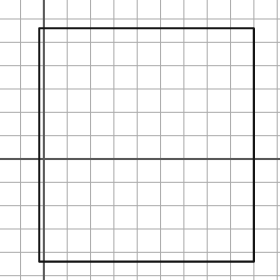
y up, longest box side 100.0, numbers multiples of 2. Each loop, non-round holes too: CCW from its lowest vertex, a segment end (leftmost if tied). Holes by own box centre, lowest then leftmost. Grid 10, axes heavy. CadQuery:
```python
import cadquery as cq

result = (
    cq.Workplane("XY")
    .moveTo(-2.0, -44.0)
    .lineTo(90.0, -44.0)
    .lineTo(90.0, 56.0)
    .lineTo(-2.0, 56.0)
    .close()
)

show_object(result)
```